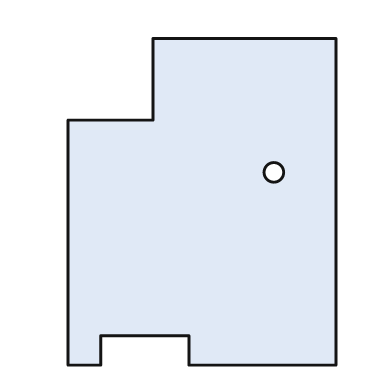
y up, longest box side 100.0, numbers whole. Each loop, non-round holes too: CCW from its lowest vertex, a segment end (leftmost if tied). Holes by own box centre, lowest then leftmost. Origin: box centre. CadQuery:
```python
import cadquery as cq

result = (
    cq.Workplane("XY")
    .moveTo(-41.0, -50.0)
    .lineTo(-31.0, -50.0)
    .lineTo(-31.0, -41.0)
    .lineTo(-4.0, -41.0)
    .lineTo(-4.0, -50.0)
    .lineTo(41.0, -50.0)
    .lineTo(41.0, 50.0)
    .lineTo(-15.0, 50.0)
    .lineTo(-15.0, 25.0)
    .lineTo(-41.0, 25.0)
    .close()
    .moveTo(22.0, 9.0)
    .circle(3.0)
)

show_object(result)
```